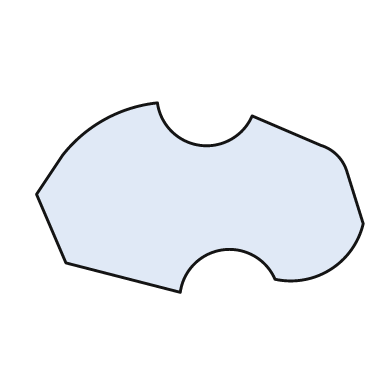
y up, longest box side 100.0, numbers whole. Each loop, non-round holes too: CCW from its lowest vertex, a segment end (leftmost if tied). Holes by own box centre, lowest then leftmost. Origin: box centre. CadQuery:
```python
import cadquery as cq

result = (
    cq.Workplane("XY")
    .moveTo(-6.0, -29.0)
    .threePointArc((7.0, -16.0), (23.0, -25.0))
    .threePointArc((40.0, -22.0), (50.0, -8.0))
    .lineTo(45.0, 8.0)
    .threePointArc((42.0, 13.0), (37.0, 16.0))
    .lineTo(16.0, 25.0)
    .threePointArc((0.0, 16.0), (-13.0, 29.0))
    .threePointArc((-29.0, 24.0), (-42.0, 13.0))
    .lineTo(-50.0, 1.0)
    .lineTo(-41.0, -20.0)
    .close()
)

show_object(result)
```